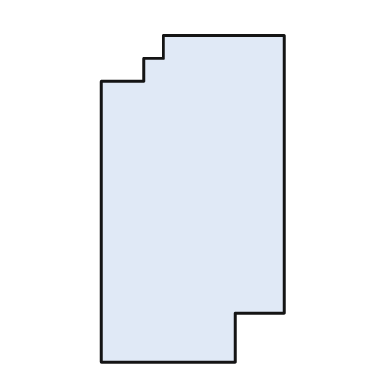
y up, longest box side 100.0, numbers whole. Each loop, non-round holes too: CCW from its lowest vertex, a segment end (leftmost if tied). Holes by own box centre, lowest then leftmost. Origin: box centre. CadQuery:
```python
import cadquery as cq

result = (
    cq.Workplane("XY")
    .moveTo(-28.0, -50.0)
    .lineTo(13.0, -50.0)
    .lineTo(13.0, -35.0)
    .lineTo(28.0, -35.0)
    .lineTo(28.0, 50.0)
    .lineTo(-9.0, 50.0)
    .lineTo(-9.0, 43.0)
    .lineTo(-15.0, 43.0)
    .lineTo(-15.0, 36.0)
    .lineTo(-28.0, 36.0)
    .close()
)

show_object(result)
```